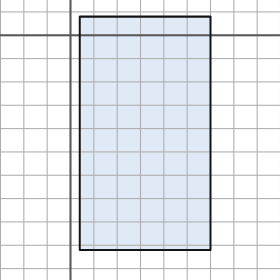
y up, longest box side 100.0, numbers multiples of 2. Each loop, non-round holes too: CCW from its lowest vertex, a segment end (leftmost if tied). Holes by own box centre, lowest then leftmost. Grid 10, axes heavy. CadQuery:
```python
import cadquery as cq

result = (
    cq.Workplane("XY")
    .moveTo(4.0, -92.0)
    .lineTo(60.0, -92.0)
    .lineTo(60.0, 8.0)
    .lineTo(4.0, 8.0)
    .close()
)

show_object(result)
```